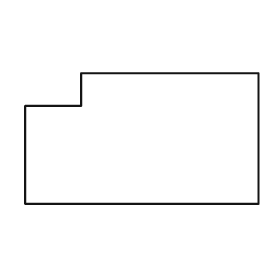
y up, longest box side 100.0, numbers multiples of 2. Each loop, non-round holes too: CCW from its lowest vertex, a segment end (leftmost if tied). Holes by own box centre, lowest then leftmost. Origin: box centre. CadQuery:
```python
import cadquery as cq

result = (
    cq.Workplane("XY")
    .moveTo(-50.0, -28.0)
    .lineTo(50.0, -28.0)
    .lineTo(50.0, 28.0)
    .lineTo(-26.0, 28.0)
    .lineTo(-26.0, 14.0)
    .lineTo(-50.0, 14.0)
    .close()
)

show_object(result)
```